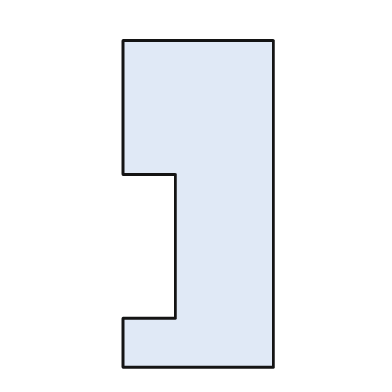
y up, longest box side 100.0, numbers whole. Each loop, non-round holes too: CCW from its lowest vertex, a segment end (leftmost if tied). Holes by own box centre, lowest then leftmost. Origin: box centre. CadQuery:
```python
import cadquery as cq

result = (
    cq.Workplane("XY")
    .moveTo(-23.0, -50.0)
    .lineTo(23.0, -50.0)
    .lineTo(23.0, 50.0)
    .lineTo(-23.0, 50.0)
    .lineTo(-23.0, 9.0)
    .lineTo(-7.0, 9.0)
    .lineTo(-7.0, -35.0)
    .lineTo(-23.0, -35.0)
    .close()
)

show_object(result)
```